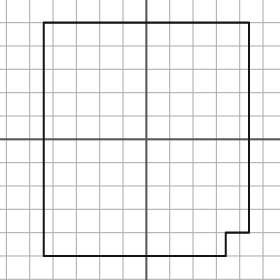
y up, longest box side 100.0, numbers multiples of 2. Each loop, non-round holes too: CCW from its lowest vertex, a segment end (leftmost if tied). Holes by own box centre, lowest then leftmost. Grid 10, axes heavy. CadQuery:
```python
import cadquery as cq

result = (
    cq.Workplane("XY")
    .moveTo(-44.0, -50.0)
    .lineTo(34.0, -50.0)
    .lineTo(34.0, -40.0)
    .lineTo(44.0, -40.0)
    .lineTo(44.0, 50.0)
    .lineTo(-44.0, 50.0)
    .close()
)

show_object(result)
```